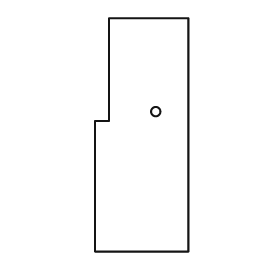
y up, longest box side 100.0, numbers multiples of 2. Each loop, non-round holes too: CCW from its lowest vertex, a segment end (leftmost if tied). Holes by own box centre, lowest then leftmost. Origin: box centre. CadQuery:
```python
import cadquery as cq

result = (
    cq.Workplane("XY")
    .moveTo(-20.0, -50.0)
    .lineTo(20.0, -50.0)
    .lineTo(20.0, 50.0)
    .lineTo(-14.0, 50.0)
    .lineTo(-14.0, 6.0)
    .lineTo(-20.0, 6.0)
    .close()
    .moveTo(6.0, 10.0)
    .circle(2.0)
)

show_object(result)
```